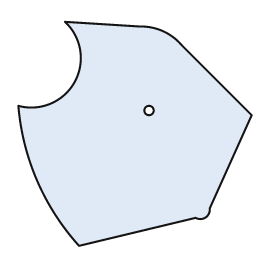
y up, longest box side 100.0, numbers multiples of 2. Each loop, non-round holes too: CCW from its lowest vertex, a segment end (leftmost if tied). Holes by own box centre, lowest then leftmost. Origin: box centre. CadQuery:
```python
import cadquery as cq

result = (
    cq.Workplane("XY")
    .moveTo(-24.0, -48.0)
    .lineTo(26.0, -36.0)
    .threePointArc((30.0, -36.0), (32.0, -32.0))
    .lineTo(50.0, 8.0)
    .lineTo(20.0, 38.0)
    .threePointArc((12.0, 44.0), (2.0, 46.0))
    .lineTo(-30.0, 48.0)
    .threePointArc((-26.0, 22.0), (-50.0, 12.0))
    .threePointArc((-42.0, -20.0), (-24.0, -48.0))
    .close()
    .moveTo(6.0, 10.0)
    .circle(2.0)
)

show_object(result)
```